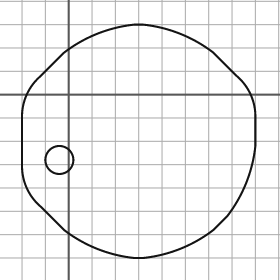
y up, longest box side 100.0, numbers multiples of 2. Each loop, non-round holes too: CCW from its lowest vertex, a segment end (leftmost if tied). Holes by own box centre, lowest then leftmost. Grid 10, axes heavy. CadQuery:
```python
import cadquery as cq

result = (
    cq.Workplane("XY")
    .moveTo(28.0, -70.0)
    .lineTo(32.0, -70.0)
    .threePointArc((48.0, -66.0), (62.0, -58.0))
    .lineTo(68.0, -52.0)
    .threePointArc((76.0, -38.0), (80.0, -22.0))
    .lineTo(80.0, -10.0)
    .threePointArc((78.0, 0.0), (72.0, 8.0))
    .lineTo(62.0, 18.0)
    .threePointArc((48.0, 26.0), (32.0, 30.0))
    .lineTo(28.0, 30.0)
    .threePointArc((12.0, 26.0), (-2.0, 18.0))
    .lineTo(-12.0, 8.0)
    .threePointArc((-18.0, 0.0), (-20.0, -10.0))
    .lineTo(-20.0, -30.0)
    .threePointArc((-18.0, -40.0), (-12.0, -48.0))
    .lineTo(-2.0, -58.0)
    .threePointArc((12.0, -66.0), (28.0, -70.0))
    .close()
    .moveTo(-4.0, -28.0)
    .circle(6.0)
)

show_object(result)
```